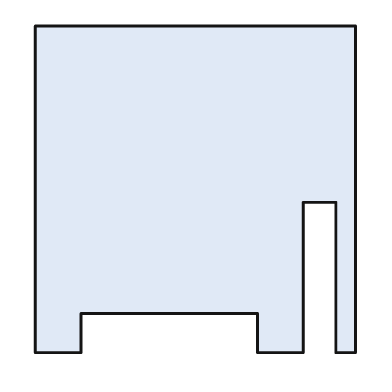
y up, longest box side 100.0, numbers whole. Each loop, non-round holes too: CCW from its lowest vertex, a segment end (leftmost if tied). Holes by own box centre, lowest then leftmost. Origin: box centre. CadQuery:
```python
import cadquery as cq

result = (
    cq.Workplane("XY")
    .moveTo(-49.0, -50.0)
    .lineTo(-35.0, -50.0)
    .lineTo(-35.0, -38.0)
    .lineTo(19.0, -38.0)
    .lineTo(19.0, -50.0)
    .lineTo(33.0, -50.0)
    .lineTo(33.0, -4.0)
    .lineTo(43.0, -4.0)
    .lineTo(43.0, -50.0)
    .lineTo(49.0, -50.0)
    .lineTo(49.0, 50.0)
    .lineTo(-49.0, 50.0)
    .close()
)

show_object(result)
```